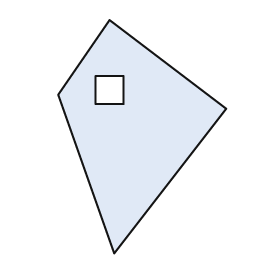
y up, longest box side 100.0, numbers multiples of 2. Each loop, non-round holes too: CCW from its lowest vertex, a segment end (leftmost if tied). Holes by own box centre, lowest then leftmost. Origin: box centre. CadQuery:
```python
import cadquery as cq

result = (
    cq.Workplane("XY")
    .moveTo(-12.0, -50.0)
    .lineTo(36.0, 12.0)
    .lineTo(-14.0, 50.0)
    .lineTo(-36.0, 18.0)
    .close()
    .moveTo(-20.0, 14.0)
    .lineTo(-8.0, 14.0)
    .lineTo(-8.0, 26.0)
    .lineTo(-20.0, 26.0)
    .close()
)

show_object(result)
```